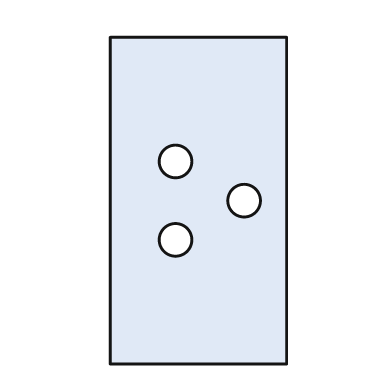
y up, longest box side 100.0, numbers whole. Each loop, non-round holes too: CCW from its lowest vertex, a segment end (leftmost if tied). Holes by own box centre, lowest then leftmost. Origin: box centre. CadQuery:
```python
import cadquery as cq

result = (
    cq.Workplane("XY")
    .moveTo(-27.0, -50.0)
    .lineTo(27.0, -50.0)
    .lineTo(27.0, 50.0)
    .lineTo(-27.0, 50.0)
    .close()
    .moveTo(-7.0, -12.0)
    .circle(5.0)
    .moveTo(14.0, 0.0)
    .circle(5.0)
    .moveTo(-7.0, 12.0)
    .circle(5.0)
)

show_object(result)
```